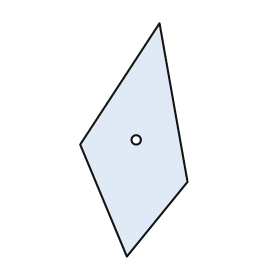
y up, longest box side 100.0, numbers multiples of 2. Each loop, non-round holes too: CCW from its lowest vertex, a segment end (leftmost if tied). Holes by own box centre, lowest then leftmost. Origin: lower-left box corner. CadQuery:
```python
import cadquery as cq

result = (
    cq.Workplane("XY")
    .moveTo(20.0, 0.0)
    .lineTo(46.0, 32.0)
    .lineTo(34.0, 100.0)
    .lineTo(0.0, 48.0)
    .close()
    .moveTo(24.0, 50.0)
    .circle(2.0)
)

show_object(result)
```